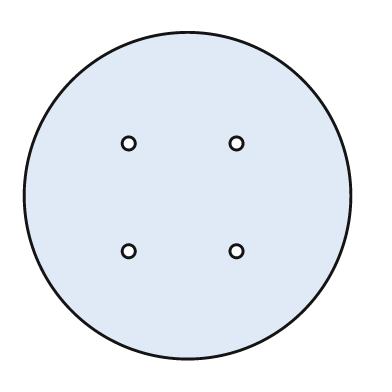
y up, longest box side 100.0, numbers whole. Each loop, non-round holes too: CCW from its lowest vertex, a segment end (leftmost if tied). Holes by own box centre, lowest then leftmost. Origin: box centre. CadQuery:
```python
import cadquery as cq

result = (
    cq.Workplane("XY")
    .moveTo(0.0, 0.0)
    .circle(50.0)
    .moveTo(-18.0, -17.0)
    .circle(2.0)
    .moveTo(15.0, -17.0)
    .circle(2.0)
    .moveTo(-18.0, 16.0)
    .circle(2.0)
    .moveTo(15.0, 16.0)
    .circle(2.0)
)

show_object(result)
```